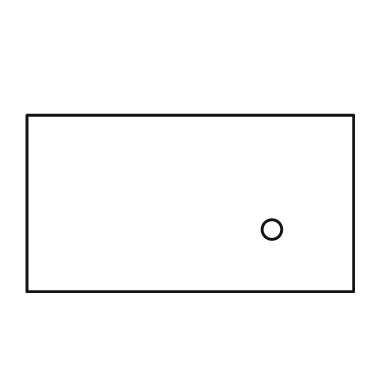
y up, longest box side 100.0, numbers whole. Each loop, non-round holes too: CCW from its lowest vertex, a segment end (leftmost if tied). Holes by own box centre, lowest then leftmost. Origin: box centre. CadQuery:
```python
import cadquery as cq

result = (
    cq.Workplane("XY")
    .moveTo(-50.0, -27.0)
    .lineTo(50.0, -27.0)
    .lineTo(50.0, 27.0)
    .lineTo(-50.0, 27.0)
    .close()
    .moveTo(25.0, -8.0)
    .circle(3.0)
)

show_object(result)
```